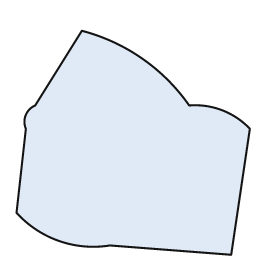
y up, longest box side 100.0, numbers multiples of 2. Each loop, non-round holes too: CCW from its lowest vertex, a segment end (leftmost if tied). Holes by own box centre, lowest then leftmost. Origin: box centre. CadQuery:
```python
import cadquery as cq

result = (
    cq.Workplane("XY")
    .moveTo(42.0, -48.0)
    .lineTo(50.0, 6.0)
    .threePointArc((38.0, 14.0), (24.0, 16.0))
    .threePointArc((4.0, 36.0), (-22.0, 48.0))
    .lineTo(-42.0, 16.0)
    .threePointArc((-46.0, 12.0), (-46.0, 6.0))
    .lineTo(-50.0, -30.0)
    .threePointArc((-32.0, -42.0), (-10.0, -44.0))
    .close()
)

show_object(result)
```